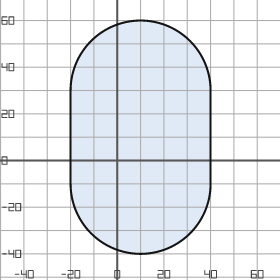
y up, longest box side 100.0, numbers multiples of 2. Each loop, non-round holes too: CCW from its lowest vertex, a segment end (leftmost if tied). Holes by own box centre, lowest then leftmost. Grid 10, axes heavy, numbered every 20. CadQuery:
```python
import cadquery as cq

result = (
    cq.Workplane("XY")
    .moveTo(-20.0, -10.0)
    .threePointArc((10.0, -40.0), (40.0, -10.0))
    .lineTo(40.0, 30.0)
    .threePointArc((10.0, 60.0), (-20.0, 30.0))
    .close()
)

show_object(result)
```